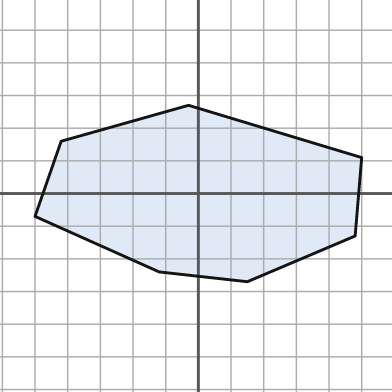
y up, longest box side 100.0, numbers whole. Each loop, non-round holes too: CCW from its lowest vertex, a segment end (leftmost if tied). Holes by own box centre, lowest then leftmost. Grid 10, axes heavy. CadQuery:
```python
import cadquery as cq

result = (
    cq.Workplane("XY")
    .moveTo(15.0, -27.0)
    .lineTo(48.0, -13.0)
    .lineTo(50.0, 11.0)
    .lineTo(-3.0, 27.0)
    .lineTo(-42.0, 16.0)
    .lineTo(-50.0, -7.0)
    .lineTo(-12.0, -24.0)
    .close()
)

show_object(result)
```